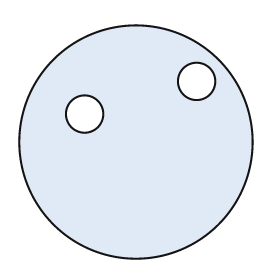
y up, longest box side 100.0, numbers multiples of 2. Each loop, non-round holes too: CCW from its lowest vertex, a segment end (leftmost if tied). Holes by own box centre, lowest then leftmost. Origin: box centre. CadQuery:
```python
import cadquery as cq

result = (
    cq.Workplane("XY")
    .moveTo(0.0, 0.0)
    .circle(50.0)
    .moveTo(-22.0, 12.0)
    .circle(8.0)
    .moveTo(26.0, 26.0)
    .circle(8.0)
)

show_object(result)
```